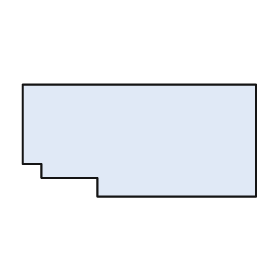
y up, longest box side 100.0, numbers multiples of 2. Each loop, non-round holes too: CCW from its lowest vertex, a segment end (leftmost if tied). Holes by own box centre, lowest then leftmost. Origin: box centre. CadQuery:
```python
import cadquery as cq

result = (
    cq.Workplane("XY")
    .moveTo(-18.0, -24.0)
    .lineTo(50.0, -24.0)
    .lineTo(50.0, 24.0)
    .lineTo(-50.0, 24.0)
    .lineTo(-50.0, -10.0)
    .lineTo(-42.0, -10.0)
    .lineTo(-42.0, -16.0)
    .lineTo(-18.0, -16.0)
    .close()
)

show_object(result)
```